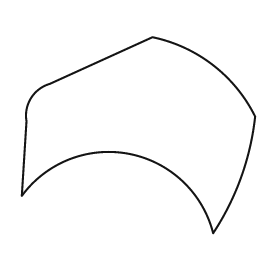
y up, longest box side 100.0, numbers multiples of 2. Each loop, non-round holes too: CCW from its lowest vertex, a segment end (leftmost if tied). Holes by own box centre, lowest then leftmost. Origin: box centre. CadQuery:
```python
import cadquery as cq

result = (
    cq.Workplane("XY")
    .moveTo(32.0, -42.0)
    .threePointArc((44.0, -18.0), (50.0, 8.0))
    .threePointArc((32.0, 30.0), (6.0, 42.0))
    .lineTo(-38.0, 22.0)
    .threePointArc((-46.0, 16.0), (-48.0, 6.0))
    .lineTo(-50.0, -26.0)
    .threePointArc((-4.0, -8.0), (32.0, -42.0))
    .close()
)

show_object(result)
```